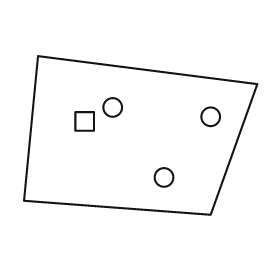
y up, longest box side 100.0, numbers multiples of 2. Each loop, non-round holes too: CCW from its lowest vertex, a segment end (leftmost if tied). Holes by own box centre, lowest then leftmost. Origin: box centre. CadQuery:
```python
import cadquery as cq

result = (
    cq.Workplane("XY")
    .moveTo(30.0, -34.0)
    .lineTo(50.0, 22.0)
    .lineTo(-44.0, 34.0)
    .lineTo(-50.0, -28.0)
    .close()
    .moveTo(10.0, -18.0)
    .circle(4.0)
    .moveTo(-28.0, 2.0)
    .lineTo(-20.0, 2.0)
    .lineTo(-20.0, 10.0)
    .lineTo(-28.0, 10.0)
    .close()
    .moveTo(30.0, 8.0)
    .circle(4.0)
    .moveTo(-12.0, 12.0)
    .circle(4.0)
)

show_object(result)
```